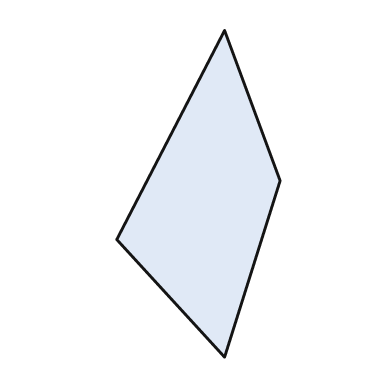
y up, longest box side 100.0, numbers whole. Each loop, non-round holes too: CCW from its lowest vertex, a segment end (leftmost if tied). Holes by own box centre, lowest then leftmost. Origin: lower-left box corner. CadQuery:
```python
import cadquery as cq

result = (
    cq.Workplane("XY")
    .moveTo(33.0, 0.0)
    .lineTo(50.0, 54.0)
    .lineTo(33.0, 100.0)
    .lineTo(0.0, 36.0)
    .close()
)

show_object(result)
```